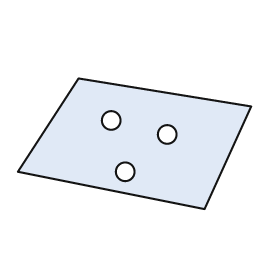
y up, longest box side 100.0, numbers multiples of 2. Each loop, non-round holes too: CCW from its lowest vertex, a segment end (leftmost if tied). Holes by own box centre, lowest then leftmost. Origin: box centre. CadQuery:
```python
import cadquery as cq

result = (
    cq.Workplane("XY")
    .moveTo(30.0, -28.0)
    .lineTo(50.0, 16.0)
    .lineTo(-24.0, 28.0)
    .lineTo(-50.0, -12.0)
    .close()
    .moveTo(-4.0, -12.0)
    .circle(4.0)
    .moveTo(14.0, 4.0)
    .circle(4.0)
    .moveTo(-10.0, 10.0)
    .circle(4.0)
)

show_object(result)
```